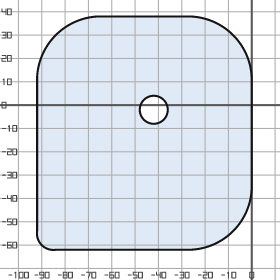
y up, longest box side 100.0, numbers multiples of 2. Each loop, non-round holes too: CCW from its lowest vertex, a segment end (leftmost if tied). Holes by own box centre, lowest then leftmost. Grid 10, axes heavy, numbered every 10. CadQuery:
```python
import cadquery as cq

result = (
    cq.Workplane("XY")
    .moveTo(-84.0, -62.0)
    .lineTo(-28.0, -62.0)
    .threePointArc((-8.0, -54.0), (0.0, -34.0))
    .lineTo(0.0, 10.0)
    .threePointArc((-8.0, 30.0), (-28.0, 38.0))
    .lineTo(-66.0, 38.0)
    .threePointArc((-84.0, 30.0), (-92.0, 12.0))
    .lineTo(-92.0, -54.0)
    .threePointArc((-90.0, -60.0), (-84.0, -62.0))
    .close()
    .moveTo(-42.0, -2.0)
    .circle(6.0)
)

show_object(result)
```